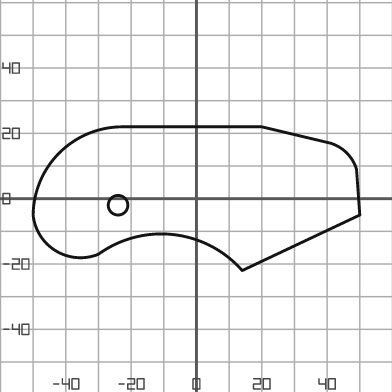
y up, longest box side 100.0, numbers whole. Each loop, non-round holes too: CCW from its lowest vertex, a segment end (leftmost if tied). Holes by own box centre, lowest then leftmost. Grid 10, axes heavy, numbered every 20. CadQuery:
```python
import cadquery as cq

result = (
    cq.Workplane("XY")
    .moveTo(14.0, -22.0)
    .lineTo(50.0, -5.0)
    .lineTo(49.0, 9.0)
    .threePointArc((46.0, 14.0), (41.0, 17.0))
    .lineTo(20.0, 22.0)
    .lineTo(-23.0, 22.0)
    .threePointArc((-42.0, 14.0), (-50.0, -5.0))
    .threePointArc((-43.0, -16.0), (-30.0, -17.0))
    .threePointArc((-7.0, -11.0), (14.0, -22.0))
    .close()
    .moveTo(-24.0, -2.0)
    .circle(3.0)
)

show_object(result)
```